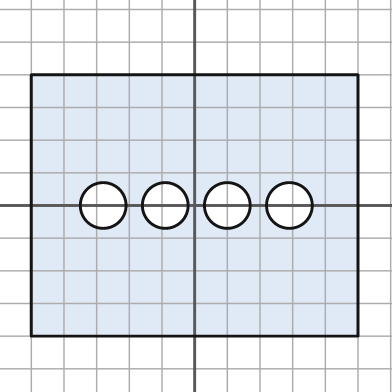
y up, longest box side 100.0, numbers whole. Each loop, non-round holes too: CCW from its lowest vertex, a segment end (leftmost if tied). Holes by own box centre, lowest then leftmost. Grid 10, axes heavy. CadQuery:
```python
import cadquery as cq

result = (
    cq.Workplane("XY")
    .moveTo(-50.0, -40.0)
    .lineTo(50.0, -40.0)
    .lineTo(50.0, 40.0)
    .lineTo(-50.0, 40.0)
    .close()
    .moveTo(-28.0, 0.0)
    .circle(7.0)
    .moveTo(-9.0, 0.0)
    .circle(7.0)
    .moveTo(10.0, 0.0)
    .circle(7.0)
    .moveTo(29.0, 0.0)
    .circle(7.0)
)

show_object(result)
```